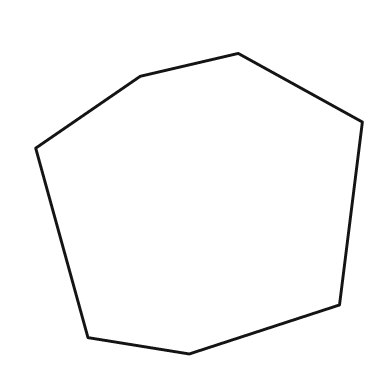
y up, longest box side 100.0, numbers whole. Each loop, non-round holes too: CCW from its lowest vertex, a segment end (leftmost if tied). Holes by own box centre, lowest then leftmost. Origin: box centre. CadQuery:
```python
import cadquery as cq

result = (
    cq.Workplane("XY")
    .moveTo(-3.0, -46.0)
    .lineTo(43.0, -31.0)
    .lineTo(50.0, 25.0)
    .lineTo(12.0, 46.0)
    .lineTo(-18.0, 39.0)
    .lineTo(-50.0, 17.0)
    .lineTo(-34.0, -41.0)
    .close()
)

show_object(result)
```